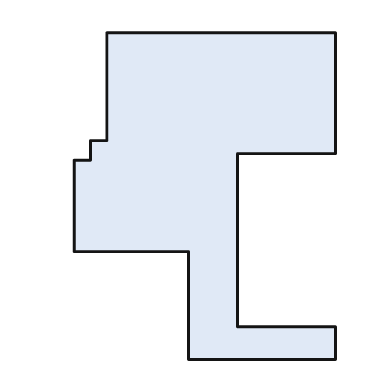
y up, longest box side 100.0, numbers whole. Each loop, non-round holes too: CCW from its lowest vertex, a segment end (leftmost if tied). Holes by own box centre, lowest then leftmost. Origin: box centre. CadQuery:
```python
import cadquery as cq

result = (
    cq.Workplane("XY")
    .moveTo(-5.0, -50.0)
    .lineTo(40.0, -50.0)
    .lineTo(40.0, -40.0)
    .lineTo(10.0, -40.0)
    .lineTo(10.0, 13.0)
    .lineTo(40.0, 13.0)
    .lineTo(40.0, 50.0)
    .lineTo(-30.0, 50.0)
    .lineTo(-30.0, 17.0)
    .lineTo(-35.0, 17.0)
    .lineTo(-35.0, 11.0)
    .lineTo(-40.0, 11.0)
    .lineTo(-40.0, -17.0)
    .lineTo(-5.0, -17.0)
    .close()
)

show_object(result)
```